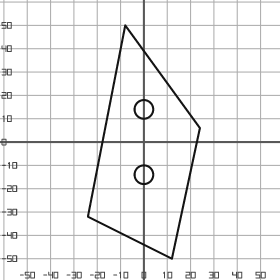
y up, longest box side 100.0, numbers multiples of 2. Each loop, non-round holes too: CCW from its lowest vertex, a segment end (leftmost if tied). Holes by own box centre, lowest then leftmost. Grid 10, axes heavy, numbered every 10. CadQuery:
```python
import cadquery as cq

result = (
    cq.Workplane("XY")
    .moveTo(12.0, -50.0)
    .lineTo(24.0, 6.0)
    .lineTo(-8.0, 50.0)
    .lineTo(-24.0, -32.0)
    .close()
    .moveTo(0.0, -14.0)
    .circle(4.0)
    .moveTo(0.0, 14.0)
    .circle(4.0)
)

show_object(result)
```